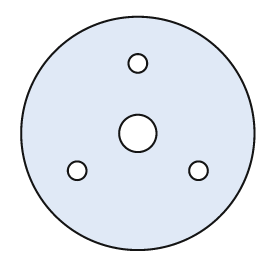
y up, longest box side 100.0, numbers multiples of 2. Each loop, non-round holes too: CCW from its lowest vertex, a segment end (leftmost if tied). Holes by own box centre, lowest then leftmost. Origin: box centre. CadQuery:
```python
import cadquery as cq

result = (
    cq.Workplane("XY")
    .moveTo(0.0, 0.0)
    .circle(50.0)
    .moveTo(-26.0, -16.0)
    .circle(4.0)
    .moveTo(26.0, -16.0)
    .circle(4.0)
    .moveTo(0.0, 0.0)
    .circle(8.0)
    .moveTo(0.0, 30.0)
    .circle(4.0)
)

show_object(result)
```